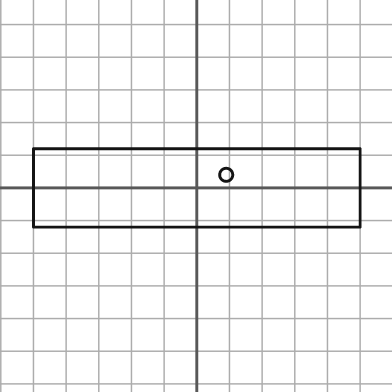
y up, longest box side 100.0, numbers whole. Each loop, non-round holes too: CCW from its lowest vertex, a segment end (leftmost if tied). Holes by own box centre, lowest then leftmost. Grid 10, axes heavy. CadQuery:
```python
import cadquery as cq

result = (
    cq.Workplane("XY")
    .moveTo(-50.0, -12.0)
    .lineTo(50.0, -12.0)
    .lineTo(50.0, 12.0)
    .lineTo(-50.0, 12.0)
    .close()
    .moveTo(9.0, 4.0)
    .circle(2.0)
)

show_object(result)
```